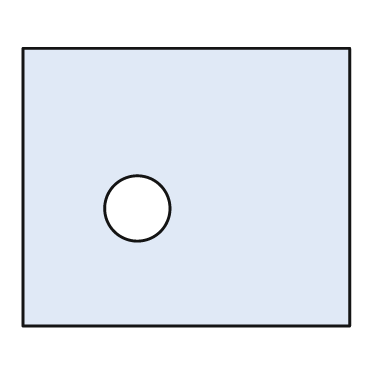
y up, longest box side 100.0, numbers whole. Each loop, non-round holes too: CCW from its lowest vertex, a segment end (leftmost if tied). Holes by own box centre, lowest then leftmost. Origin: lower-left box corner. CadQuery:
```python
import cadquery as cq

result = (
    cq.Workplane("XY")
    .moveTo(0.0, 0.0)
    .lineTo(100.0, 0.0)
    .lineTo(100.0, 85.0)
    .lineTo(0.0, 85.0)
    .close()
    .moveTo(35.0, 36.0)
    .circle(10.0)
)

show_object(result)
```